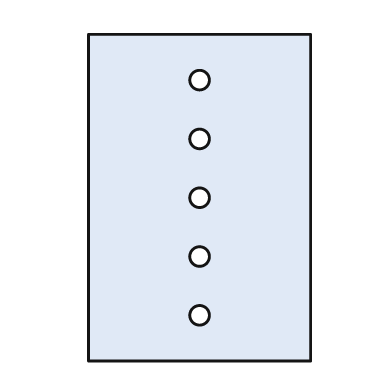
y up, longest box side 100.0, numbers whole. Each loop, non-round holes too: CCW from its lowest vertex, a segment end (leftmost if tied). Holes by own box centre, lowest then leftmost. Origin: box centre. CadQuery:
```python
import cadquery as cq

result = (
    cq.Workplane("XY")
    .moveTo(-34.0, -50.0)
    .lineTo(34.0, -50.0)
    .lineTo(34.0, 50.0)
    .lineTo(-34.0, 50.0)
    .close()
    .moveTo(0.0, -36.0)
    .circle(3.0)
    .moveTo(0.0, -18.0)
    .circle(3.0)
    .moveTo(0.0, 0.0)
    .circle(3.0)
    .moveTo(0.0, 18.0)
    .circle(3.0)
    .moveTo(0.0, 36.0)
    .circle(3.0)
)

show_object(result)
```